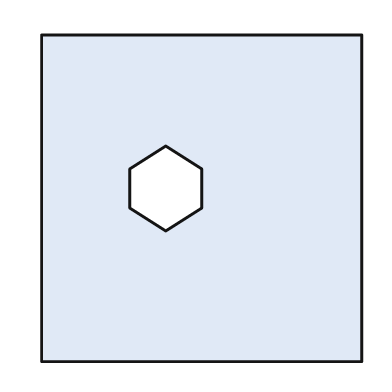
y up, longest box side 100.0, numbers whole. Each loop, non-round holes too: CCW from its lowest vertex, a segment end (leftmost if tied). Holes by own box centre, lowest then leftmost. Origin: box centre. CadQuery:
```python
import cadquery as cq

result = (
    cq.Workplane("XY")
    .moveTo(-49.0, -50.0)
    .lineTo(49.0, -50.0)
    .lineTo(49.0, 50.0)
    .lineTo(-49.0, 50.0)
    .close()
    .moveTo(-11.0, -10.0)
    .lineTo(0.0, -3.0)
    .lineTo(0.0, 9.0)
    .lineTo(-11.0, 16.0)
    .lineTo(-22.0, 9.0)
    .lineTo(-22.0, -3.0)
    .close()
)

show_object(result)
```